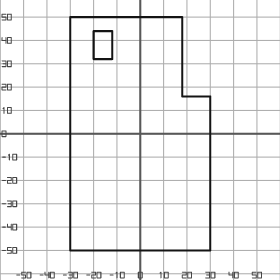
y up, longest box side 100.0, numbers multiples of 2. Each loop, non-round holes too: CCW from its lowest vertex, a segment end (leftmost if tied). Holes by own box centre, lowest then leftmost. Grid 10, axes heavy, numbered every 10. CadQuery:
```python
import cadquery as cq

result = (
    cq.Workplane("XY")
    .moveTo(-30.0, -50.0)
    .lineTo(30.0, -50.0)
    .lineTo(30.0, 16.0)
    .lineTo(18.0, 16.0)
    .lineTo(18.0, 50.0)
    .lineTo(-30.0, 50.0)
    .close()
    .moveTo(-20.0, 32.0)
    .lineTo(-12.0, 32.0)
    .lineTo(-12.0, 44.0)
    .lineTo(-20.0, 44.0)
    .close()
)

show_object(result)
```